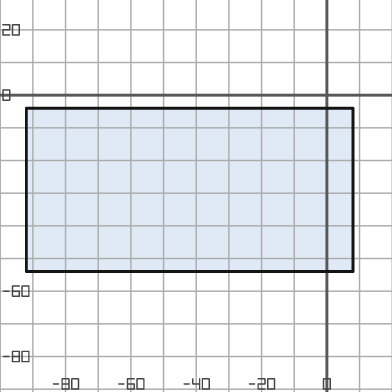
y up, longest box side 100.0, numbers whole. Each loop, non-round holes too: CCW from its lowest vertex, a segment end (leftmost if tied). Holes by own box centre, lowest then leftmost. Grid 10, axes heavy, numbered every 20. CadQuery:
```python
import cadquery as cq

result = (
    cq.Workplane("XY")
    .moveTo(-92.0, -54.0)
    .lineTo(8.0, -54.0)
    .lineTo(8.0, -4.0)
    .lineTo(-92.0, -4.0)
    .close()
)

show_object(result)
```